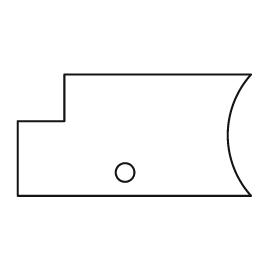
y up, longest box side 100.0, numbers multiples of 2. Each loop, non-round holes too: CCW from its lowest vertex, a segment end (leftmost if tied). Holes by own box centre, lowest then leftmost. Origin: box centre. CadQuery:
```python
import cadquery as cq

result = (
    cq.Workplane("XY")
    .moveTo(-50.0, -26.0)
    .lineTo(50.0, -26.0)
    .threePointArc((40.0, 0.0), (50.0, 26.0))
    .lineTo(-30.0, 26.0)
    .lineTo(-30.0, 6.0)
    .lineTo(-50.0, 6.0)
    .close()
    .moveTo(-4.0, -16.0)
    .circle(4.0)
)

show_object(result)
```